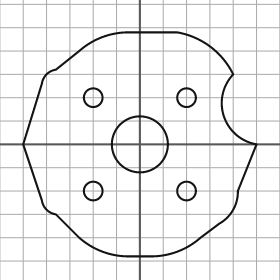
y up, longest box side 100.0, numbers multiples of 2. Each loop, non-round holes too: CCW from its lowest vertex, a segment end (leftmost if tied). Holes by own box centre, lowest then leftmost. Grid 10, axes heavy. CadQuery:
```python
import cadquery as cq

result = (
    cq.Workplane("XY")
    .moveTo(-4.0, -48.0)
    .lineTo(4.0, -48.0)
    .threePointArc((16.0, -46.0), (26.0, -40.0))
    .lineTo(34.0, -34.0)
    .threePointArc((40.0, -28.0), (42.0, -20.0))
    .lineTo(50.0, 0.0)
    .threePointArc((36.0, 12.0), (40.0, 30.0))
    .threePointArc((30.0, 42.0), (16.0, 48.0))
    .lineTo(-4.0, 48.0)
    .threePointArc((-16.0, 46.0), (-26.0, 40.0))
    .lineTo(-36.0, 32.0)
    .threePointArc((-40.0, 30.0), (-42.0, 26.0))
    .lineTo(-50.0, 0.0)
    .lineTo(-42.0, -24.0)
    .threePointArc((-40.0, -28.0), (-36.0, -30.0))
    .lineTo(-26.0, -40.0)
    .threePointArc((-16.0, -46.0), (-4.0, -48.0))
    .close()
    .moveTo(-20.0, -20.0)
    .circle(4.0)
    .moveTo(20.0, -20.0)
    .circle(4.0)
    .moveTo(0.0, 0.0)
    .circle(12.0)
    .moveTo(-20.0, 20.0)
    .circle(4.0)
    .moveTo(20.0, 20.0)
    .circle(4.0)
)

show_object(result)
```